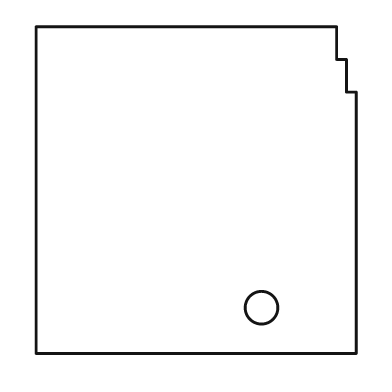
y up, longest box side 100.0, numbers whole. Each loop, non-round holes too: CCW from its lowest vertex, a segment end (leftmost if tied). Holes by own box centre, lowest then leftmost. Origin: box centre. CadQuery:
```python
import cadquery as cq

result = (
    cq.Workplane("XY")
    .moveTo(-49.0, -50.0)
    .lineTo(49.0, -50.0)
    .lineTo(49.0, 30.0)
    .lineTo(46.0, 30.0)
    .lineTo(46.0, 40.0)
    .lineTo(43.0, 40.0)
    .lineTo(43.0, 50.0)
    .lineTo(-49.0, 50.0)
    .close()
    .moveTo(20.0, -36.0)
    .circle(5.0)
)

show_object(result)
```